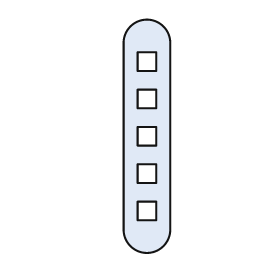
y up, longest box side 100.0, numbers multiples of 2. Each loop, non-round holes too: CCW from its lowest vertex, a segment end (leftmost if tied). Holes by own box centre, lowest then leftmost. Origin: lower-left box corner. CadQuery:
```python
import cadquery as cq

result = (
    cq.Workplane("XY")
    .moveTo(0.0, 10.0)
    .threePointArc((10.0, 0.0), (20.0, 10.0))
    .lineTo(20.0, 90.0)
    .threePointArc((10.0, 100.0), (0.0, 90.0))
    .close()
    .moveTo(6.0, 14.0)
    .lineTo(14.0, 14.0)
    .lineTo(14.0, 22.0)
    .lineTo(6.0, 22.0)
    .close()
    .moveTo(6.0, 30.0)
    .lineTo(14.0, 30.0)
    .lineTo(14.0, 38.0)
    .lineTo(6.0, 38.0)
    .close()
    .moveTo(6.0, 46.0)
    .lineTo(14.0, 46.0)
    .lineTo(14.0, 54.0)
    .lineTo(6.0, 54.0)
    .close()
    .moveTo(6.0, 62.0)
    .lineTo(14.0, 62.0)
    .lineTo(14.0, 70.0)
    .lineTo(6.0, 70.0)
    .close()
    .moveTo(6.0, 78.0)
    .lineTo(14.0, 78.0)
    .lineTo(14.0, 86.0)
    .lineTo(6.0, 86.0)
    .close()
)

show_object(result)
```